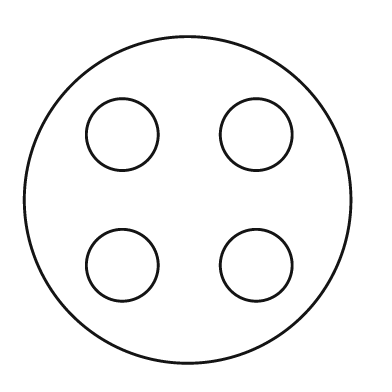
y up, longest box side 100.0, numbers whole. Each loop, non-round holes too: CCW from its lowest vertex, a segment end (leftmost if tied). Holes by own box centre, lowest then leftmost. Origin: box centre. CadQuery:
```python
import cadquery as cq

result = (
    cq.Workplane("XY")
    .moveTo(0.0, 0.0)
    .circle(50.0)
    .moveTo(-20.0, -20.0)
    .circle(11.0)
    .moveTo(21.0, -20.0)
    .circle(11.0)
    .moveTo(-20.0, 20.0)
    .circle(11.0)
    .moveTo(21.0, 20.0)
    .circle(11.0)
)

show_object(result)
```